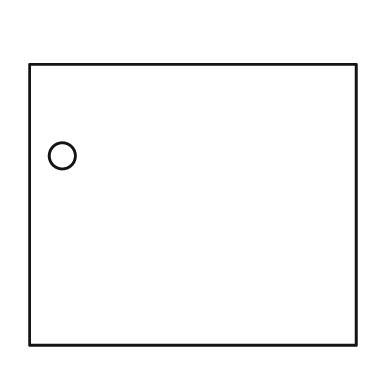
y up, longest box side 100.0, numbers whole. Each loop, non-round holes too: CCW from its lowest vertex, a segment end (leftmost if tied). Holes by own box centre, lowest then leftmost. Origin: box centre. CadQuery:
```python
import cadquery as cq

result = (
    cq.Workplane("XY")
    .moveTo(-50.0, -43.0)
    .lineTo(50.0, -43.0)
    .lineTo(50.0, 43.0)
    .lineTo(-50.0, 43.0)
    .close()
    .moveTo(-40.0, 15.0)
    .circle(4.0)
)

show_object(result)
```